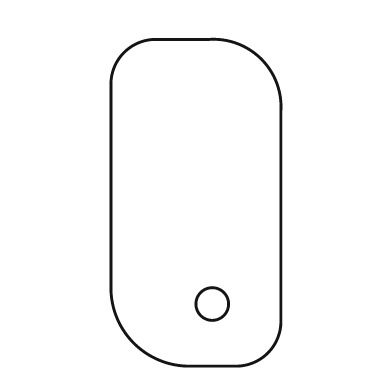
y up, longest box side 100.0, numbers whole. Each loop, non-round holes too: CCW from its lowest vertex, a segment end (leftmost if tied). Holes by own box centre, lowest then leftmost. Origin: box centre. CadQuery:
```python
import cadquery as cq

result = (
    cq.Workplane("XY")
    .moveTo(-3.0, -50.0)
    .lineTo(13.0, -50.0)
    .threePointArc((22.0, -46.0), (26.0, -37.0))
    .lineTo(26.0, 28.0)
    .threePointArc((20.0, 44.0), (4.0, 50.0))
    .lineTo(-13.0, 50.0)
    .threePointArc((-22.0, 46.0), (-26.0, 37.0))
    .lineTo(-26.0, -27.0)
    .threePointArc((-19.0, -43.0), (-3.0, -50.0))
    .close()
    .moveTo(5.0, -31.0)
    .circle(5.0)
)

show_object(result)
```